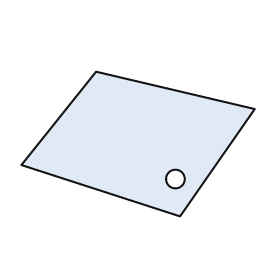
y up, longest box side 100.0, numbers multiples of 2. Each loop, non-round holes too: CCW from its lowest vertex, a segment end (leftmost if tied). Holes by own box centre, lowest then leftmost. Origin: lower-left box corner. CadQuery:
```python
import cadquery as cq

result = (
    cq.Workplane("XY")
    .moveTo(68.0, 0.0)
    .lineTo(100.0, 46.0)
    .lineTo(32.0, 62.0)
    .lineTo(0.0, 22.0)
    .close()
    .moveTo(66.0, 16.0)
    .circle(4.0)
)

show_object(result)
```